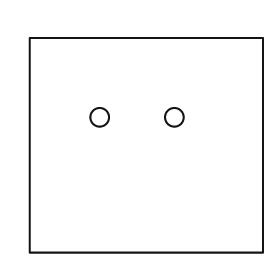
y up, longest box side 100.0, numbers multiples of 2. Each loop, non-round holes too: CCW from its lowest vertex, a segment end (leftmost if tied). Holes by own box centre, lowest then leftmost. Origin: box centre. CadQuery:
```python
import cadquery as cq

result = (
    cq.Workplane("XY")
    .moveTo(-50.0, -46.0)
    .lineTo(50.0, -46.0)
    .lineTo(50.0, 46.0)
    .lineTo(-50.0, 46.0)
    .close()
    .moveTo(-20.0, 12.0)
    .circle(4.0)
    .moveTo(12.0, 12.0)
    .circle(4.0)
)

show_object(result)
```